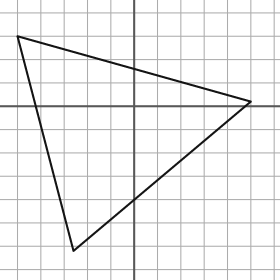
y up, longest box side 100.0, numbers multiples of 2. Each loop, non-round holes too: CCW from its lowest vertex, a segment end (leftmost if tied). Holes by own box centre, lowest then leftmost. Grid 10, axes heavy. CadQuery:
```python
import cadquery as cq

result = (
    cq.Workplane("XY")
    .moveTo(-26.0, -62.0)
    .lineTo(50.0, 2.0)
    .lineTo(-50.0, 30.0)
    .close()
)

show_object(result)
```